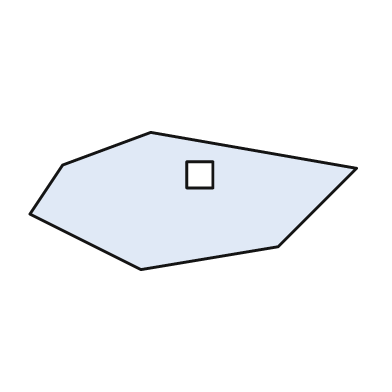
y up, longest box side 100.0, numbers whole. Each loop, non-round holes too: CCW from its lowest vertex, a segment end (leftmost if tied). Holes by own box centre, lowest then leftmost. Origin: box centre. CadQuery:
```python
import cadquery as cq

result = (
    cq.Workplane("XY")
    .moveTo(-16.0, -21.0)
    .lineTo(26.0, -14.0)
    .lineTo(50.0, 10.0)
    .lineTo(-13.0, 21.0)
    .lineTo(-40.0, 11.0)
    .lineTo(-50.0, -4.0)
    .close()
    .moveTo(-2.0, 4.0)
    .lineTo(6.0, 4.0)
    .lineTo(6.0, 12.0)
    .lineTo(-2.0, 12.0)
    .close()
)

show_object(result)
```